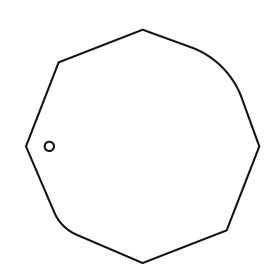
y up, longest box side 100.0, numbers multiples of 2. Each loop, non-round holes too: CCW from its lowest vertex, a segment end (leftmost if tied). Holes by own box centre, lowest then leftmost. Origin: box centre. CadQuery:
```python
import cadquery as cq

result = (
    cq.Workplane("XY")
    .moveTo(0.0, -50.0)
    .lineTo(36.0, -36.0)
    .lineTo(50.0, 0.0)
    .lineTo(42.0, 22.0)
    .threePointArc((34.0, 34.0), (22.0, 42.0))
    .lineTo(0.0, 50.0)
    .lineTo(-36.0, 36.0)
    .lineTo(-50.0, 0.0)
    .lineTo(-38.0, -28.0)
    .threePointArc((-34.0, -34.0), (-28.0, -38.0))
    .close()
    .moveTo(-40.0, 0.0)
    .circle(2.0)
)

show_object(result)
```